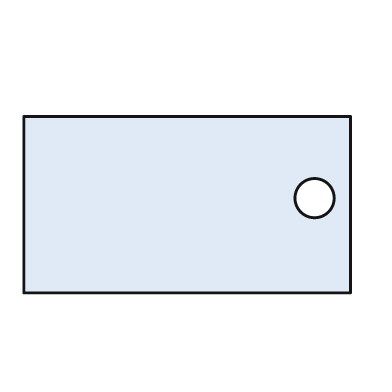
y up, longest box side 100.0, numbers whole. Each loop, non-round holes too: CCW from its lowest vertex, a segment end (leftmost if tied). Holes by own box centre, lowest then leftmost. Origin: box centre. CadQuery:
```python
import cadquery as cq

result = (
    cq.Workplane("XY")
    .moveTo(-50.0, -27.0)
    .lineTo(50.0, -27.0)
    .lineTo(50.0, 27.0)
    .lineTo(-50.0, 27.0)
    .close()
    .moveTo(39.0, 2.0)
    .circle(6.0)
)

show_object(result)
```